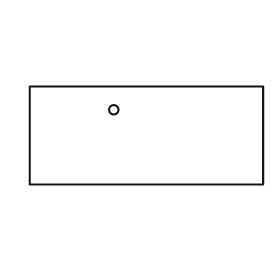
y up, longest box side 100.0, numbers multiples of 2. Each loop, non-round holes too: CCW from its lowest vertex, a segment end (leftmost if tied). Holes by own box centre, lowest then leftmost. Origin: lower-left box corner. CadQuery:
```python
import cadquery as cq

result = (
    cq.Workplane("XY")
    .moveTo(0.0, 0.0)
    .lineTo(100.0, 0.0)
    .lineTo(100.0, 42.0)
    .lineTo(0.0, 42.0)
    .close()
    .moveTo(36.0, 32.0)
    .circle(2.0)
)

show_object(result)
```